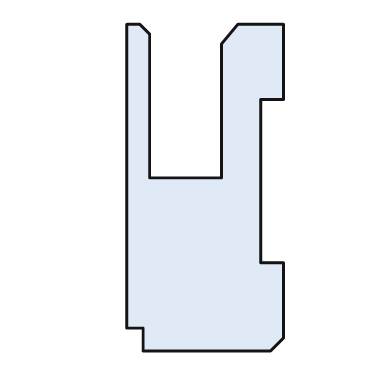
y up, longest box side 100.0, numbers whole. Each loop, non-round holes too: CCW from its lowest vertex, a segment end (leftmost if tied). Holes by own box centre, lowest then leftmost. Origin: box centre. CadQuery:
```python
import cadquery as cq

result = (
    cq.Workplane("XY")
    .moveTo(-19.0, -50.0)
    .lineTo(20.0, -50.0)
    .lineTo(24.0, -46.0)
    .lineTo(24.0, -23.0)
    .lineTo(17.0, -23.0)
    .lineTo(17.0, 27.0)
    .lineTo(24.0, 27.0)
    .lineTo(24.0, 50.0)
    .lineTo(10.0, 50.0)
    .lineTo(5.0, 44.0)
    .lineTo(5.0, 3.0)
    .lineTo(-17.0, 3.0)
    .lineTo(-17.0, 47.0)
    .lineTo(-20.0, 50.0)
    .lineTo(-24.0, 50.0)
    .lineTo(-24.0, -43.0)
    .lineTo(-19.0, -43.0)
    .close()
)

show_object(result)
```